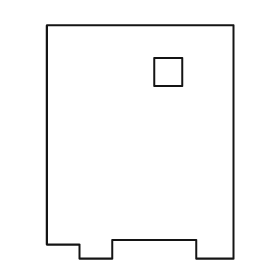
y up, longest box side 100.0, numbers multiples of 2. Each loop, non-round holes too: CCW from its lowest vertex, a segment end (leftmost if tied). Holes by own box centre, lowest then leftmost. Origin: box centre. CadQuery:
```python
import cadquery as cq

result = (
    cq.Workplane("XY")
    .moveTo(-26.0, -50.0)
    .lineTo(-12.0, -50.0)
    .lineTo(-12.0, -42.0)
    .lineTo(24.0, -42.0)
    .lineTo(24.0, -50.0)
    .lineTo(40.0, -50.0)
    .lineTo(40.0, 50.0)
    .lineTo(-40.0, 50.0)
    .lineTo(-40.0, -44.0)
    .lineTo(-26.0, -44.0)
    .close()
    .moveTo(6.0, 24.0)
    .lineTo(18.0, 24.0)
    .lineTo(18.0, 36.0)
    .lineTo(6.0, 36.0)
    .close()
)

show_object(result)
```